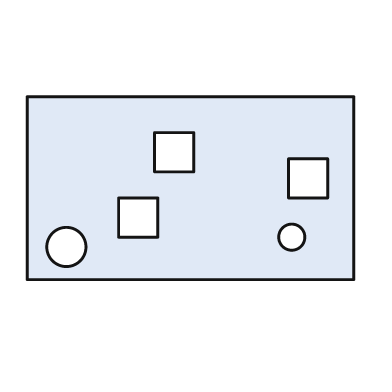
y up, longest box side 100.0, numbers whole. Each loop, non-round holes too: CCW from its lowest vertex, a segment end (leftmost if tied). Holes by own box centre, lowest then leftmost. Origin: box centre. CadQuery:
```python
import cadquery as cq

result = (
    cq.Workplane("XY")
    .moveTo(-50.0, -28.0)
    .lineTo(50.0, -28.0)
    .lineTo(50.0, 28.0)
    .lineTo(-50.0, 28.0)
    .close()
    .moveTo(-38.0, -18.0)
    .circle(6.0)
    .moveTo(31.0, -15.0)
    .circle(4.0)
    .moveTo(-22.0, -15.0)
    .lineTo(-10.0, -15.0)
    .lineTo(-10.0, -3.0)
    .lineTo(-22.0, -3.0)
    .close()
    .moveTo(30.0, -3.0)
    .lineTo(42.0, -3.0)
    .lineTo(42.0, 9.0)
    .lineTo(30.0, 9.0)
    .close()
    .moveTo(-11.0, 5.0)
    .lineTo(1.0, 5.0)
    .lineTo(1.0, 17.0)
    .lineTo(-11.0, 17.0)
    .close()
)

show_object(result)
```